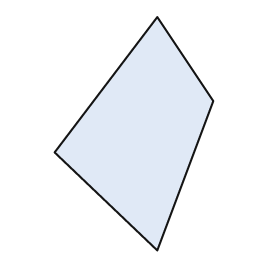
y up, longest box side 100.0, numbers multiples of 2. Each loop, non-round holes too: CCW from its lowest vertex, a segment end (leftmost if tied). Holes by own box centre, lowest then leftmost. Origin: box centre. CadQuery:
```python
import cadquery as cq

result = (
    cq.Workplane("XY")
    .moveTo(10.0, -50.0)
    .lineTo(34.0, 14.0)
    .lineTo(10.0, 50.0)
    .lineTo(-34.0, -8.0)
    .close()
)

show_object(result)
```